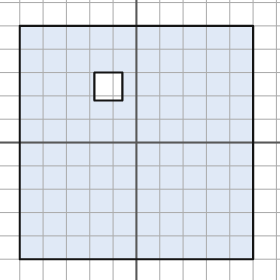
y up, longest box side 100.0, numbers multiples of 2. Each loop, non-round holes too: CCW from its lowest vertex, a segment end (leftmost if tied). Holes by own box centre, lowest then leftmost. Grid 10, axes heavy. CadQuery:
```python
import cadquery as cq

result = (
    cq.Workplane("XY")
    .moveTo(-50.0, -50.0)
    .lineTo(50.0, -50.0)
    .lineTo(50.0, 50.0)
    .lineTo(-50.0, 50.0)
    .close()
    .moveTo(-18.0, 18.0)
    .lineTo(-6.0, 18.0)
    .lineTo(-6.0, 30.0)
    .lineTo(-18.0, 30.0)
    .close()
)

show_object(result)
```